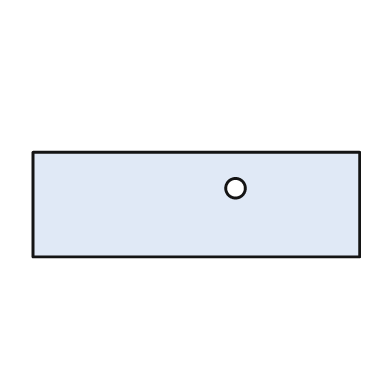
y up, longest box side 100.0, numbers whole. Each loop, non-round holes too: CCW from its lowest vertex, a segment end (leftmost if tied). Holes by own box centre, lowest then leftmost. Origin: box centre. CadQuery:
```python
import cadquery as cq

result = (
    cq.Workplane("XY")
    .moveTo(-50.0, -16.0)
    .lineTo(50.0, -16.0)
    .lineTo(50.0, 16.0)
    .lineTo(-50.0, 16.0)
    .close()
    .moveTo(12.0, 5.0)
    .circle(3.0)
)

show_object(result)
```